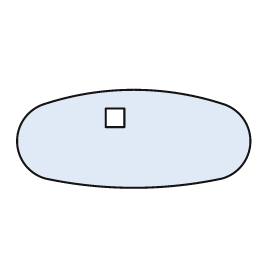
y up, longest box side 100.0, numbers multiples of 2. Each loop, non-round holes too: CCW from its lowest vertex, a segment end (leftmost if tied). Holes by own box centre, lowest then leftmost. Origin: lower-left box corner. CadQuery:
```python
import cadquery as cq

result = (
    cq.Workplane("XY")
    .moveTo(12.0, 4.0)
    .threePointArc((50.0, 0.0), (88.0, 4.0))
    .threePointArc((100.0, 20.0), (88.0, 36.0))
    .threePointArc((50.0, 42.0), (12.0, 36.0))
    .threePointArc((0.0, 20.0), (12.0, 4.0))
    .close()
    .moveTo(38.0, 26.0)
    .lineTo(46.0, 26.0)
    .lineTo(46.0, 34.0)
    .lineTo(38.0, 34.0)
    .close()
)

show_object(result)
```